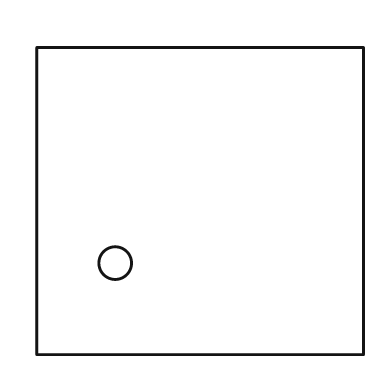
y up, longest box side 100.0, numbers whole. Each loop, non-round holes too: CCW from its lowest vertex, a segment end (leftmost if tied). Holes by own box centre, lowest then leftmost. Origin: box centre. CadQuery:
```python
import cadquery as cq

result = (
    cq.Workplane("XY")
    .moveTo(-50.0, -47.0)
    .lineTo(50.0, -47.0)
    .lineTo(50.0, 47.0)
    .lineTo(-50.0, 47.0)
    .close()
    .moveTo(-26.0, -19.0)
    .circle(5.0)
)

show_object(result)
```